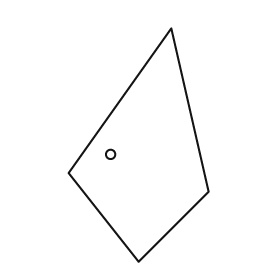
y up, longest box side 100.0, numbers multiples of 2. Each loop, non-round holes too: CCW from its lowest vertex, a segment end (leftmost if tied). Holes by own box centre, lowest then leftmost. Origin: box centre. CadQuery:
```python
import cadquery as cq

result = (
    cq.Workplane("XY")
    .moveTo(0.0, -50.0)
    .lineTo(30.0, -20.0)
    .lineTo(14.0, 50.0)
    .lineTo(-30.0, -12.0)
    .close()
    .moveTo(-12.0, -4.0)
    .circle(2.0)
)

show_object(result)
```